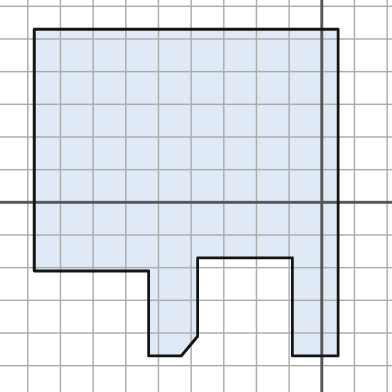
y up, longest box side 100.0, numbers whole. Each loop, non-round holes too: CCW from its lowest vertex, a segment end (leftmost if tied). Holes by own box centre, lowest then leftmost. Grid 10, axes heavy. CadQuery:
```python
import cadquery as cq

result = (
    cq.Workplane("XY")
    .moveTo(-53.0, -47.0)
    .lineTo(-43.0, -47.0)
    .lineTo(-38.0, -41.0)
    .lineTo(-38.0, -17.0)
    .lineTo(-9.0, -17.0)
    .lineTo(-9.0, -47.0)
    .lineTo(5.0, -47.0)
    .lineTo(5.0, 53.0)
    .lineTo(-88.0, 53.0)
    .lineTo(-88.0, -21.0)
    .lineTo(-53.0, -21.0)
    .close()
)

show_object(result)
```